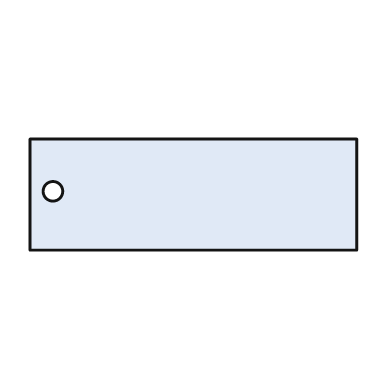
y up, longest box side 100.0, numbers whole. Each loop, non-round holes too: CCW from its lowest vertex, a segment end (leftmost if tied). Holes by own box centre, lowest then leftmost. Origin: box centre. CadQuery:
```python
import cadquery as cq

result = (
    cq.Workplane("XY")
    .moveTo(-50.0, -17.0)
    .lineTo(50.0, -17.0)
    .lineTo(50.0, 17.0)
    .lineTo(-50.0, 17.0)
    .close()
    .moveTo(-43.0, 1.0)
    .circle(3.0)
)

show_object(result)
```